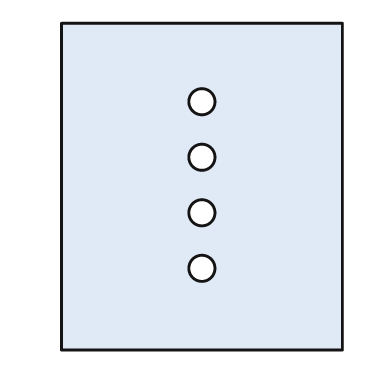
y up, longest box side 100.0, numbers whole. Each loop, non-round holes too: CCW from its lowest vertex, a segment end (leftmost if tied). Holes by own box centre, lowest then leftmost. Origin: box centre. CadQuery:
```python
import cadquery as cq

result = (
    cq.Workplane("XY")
    .moveTo(-43.0, -50.0)
    .lineTo(43.0, -50.0)
    .lineTo(43.0, 50.0)
    .lineTo(-43.0, 50.0)
    .close()
    .moveTo(0.0, -25.0)
    .circle(4.0)
    .moveTo(0.0, -8.0)
    .circle(4.0)
    .moveTo(0.0, 9.0)
    .circle(4.0)
    .moveTo(0.0, 26.0)
    .circle(4.0)
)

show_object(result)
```